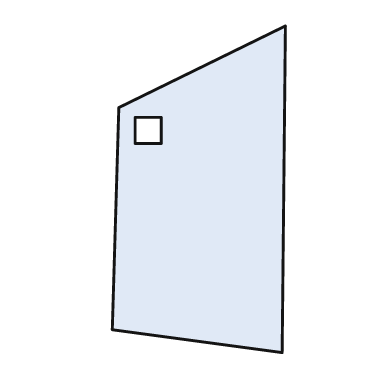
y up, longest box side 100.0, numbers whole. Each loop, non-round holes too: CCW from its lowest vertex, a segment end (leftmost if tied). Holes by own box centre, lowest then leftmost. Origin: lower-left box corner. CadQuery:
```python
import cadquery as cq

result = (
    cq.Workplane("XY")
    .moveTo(52.0, 0.0)
    .lineTo(53.0, 100.0)
    .lineTo(2.0, 75.0)
    .lineTo(0.0, 7.0)
    .close()
    .moveTo(7.0, 64.0)
    .lineTo(15.0, 64.0)
    .lineTo(15.0, 72.0)
    .lineTo(7.0, 72.0)
    .close()
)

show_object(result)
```